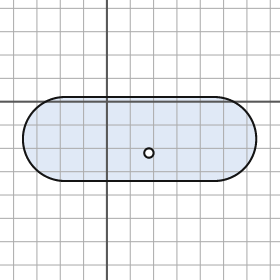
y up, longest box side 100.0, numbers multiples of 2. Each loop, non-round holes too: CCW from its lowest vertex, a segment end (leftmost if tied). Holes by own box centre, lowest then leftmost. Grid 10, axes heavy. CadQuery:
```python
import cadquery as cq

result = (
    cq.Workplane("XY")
    .moveTo(-18.0, -34.0)
    .lineTo(46.0, -34.0)
    .threePointArc((64.0, -16.0), (46.0, 2.0))
    .lineTo(-18.0, 2.0)
    .threePointArc((-36.0, -16.0), (-18.0, -34.0))
    .close()
    .moveTo(18.0, -22.0)
    .circle(2.0)
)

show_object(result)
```